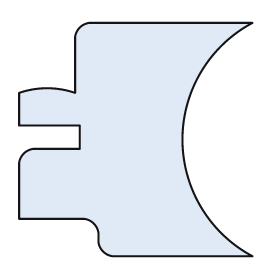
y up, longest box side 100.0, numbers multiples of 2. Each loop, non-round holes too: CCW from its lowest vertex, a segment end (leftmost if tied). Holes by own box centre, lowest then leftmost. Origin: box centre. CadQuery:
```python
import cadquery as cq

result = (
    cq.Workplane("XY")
    .moveTo(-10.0, -50.0)
    .lineTo(50.0, -50.0)
    .threePointArc((20.0, 0.0), (50.0, 50.0))
    .lineTo(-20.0, 50.0)
    .threePointArc((-24.0, 48.0), (-26.0, 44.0))
    .lineTo(-26.0, 20.0)
    .threePointArc((-38.0, 22.0), (-50.0, 20.0))
    .lineTo(-50.0, 6.0)
    .lineTo(-24.0, 6.0)
    .lineTo(-24.0, -4.0)
    .lineTo(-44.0, -4.0)
    .threePointArc((-48.0, -6.0), (-50.0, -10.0))
    .lineTo(-50.0, -34.0)
    .lineTo(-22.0, -34.0)
    .threePointArc((-18.0, -36.0), (-16.0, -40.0))
    .lineTo(-16.0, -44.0)
    .threePointArc((-14.0, -48.0), (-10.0, -50.0))
    .close()
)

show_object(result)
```